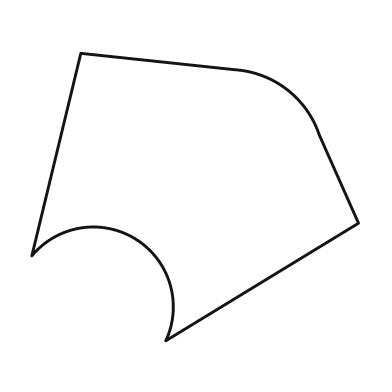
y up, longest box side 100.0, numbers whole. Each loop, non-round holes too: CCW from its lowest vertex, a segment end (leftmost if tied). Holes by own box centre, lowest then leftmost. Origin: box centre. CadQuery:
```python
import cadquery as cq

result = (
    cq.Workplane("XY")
    .moveTo(-9.0, -44.0)
    .lineTo(50.0, -8.0)
    .lineTo(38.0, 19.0)
    .threePointArc((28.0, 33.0), (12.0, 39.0))
    .lineTo(-35.0, 44.0)
    .lineTo(-50.0, -18.0)
    .threePointArc((-18.0, -13.0), (-9.0, -44.0))
    .close()
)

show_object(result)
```